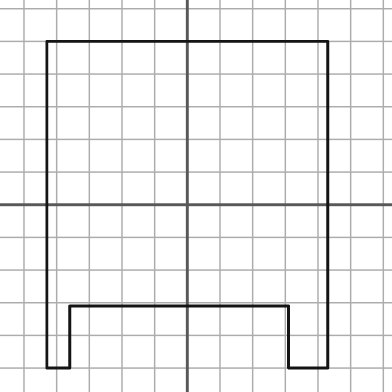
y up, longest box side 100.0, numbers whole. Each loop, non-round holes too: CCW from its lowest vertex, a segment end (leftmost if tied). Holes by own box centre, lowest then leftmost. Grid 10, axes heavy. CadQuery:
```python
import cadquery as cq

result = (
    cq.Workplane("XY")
    .moveTo(-43.0, -50.0)
    .lineTo(-36.0, -50.0)
    .lineTo(-36.0, -31.0)
    .lineTo(31.0, -31.0)
    .lineTo(31.0, -50.0)
    .lineTo(43.0, -50.0)
    .lineTo(43.0, 50.0)
    .lineTo(-43.0, 50.0)
    .close()
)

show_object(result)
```